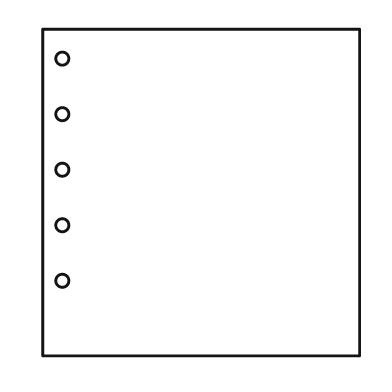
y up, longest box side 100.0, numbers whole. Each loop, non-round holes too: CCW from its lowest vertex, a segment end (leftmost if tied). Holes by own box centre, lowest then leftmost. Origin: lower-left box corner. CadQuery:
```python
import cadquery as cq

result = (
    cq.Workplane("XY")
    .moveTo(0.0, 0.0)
    .lineTo(97.0, 0.0)
    .lineTo(97.0, 100.0)
    .lineTo(0.0, 100.0)
    .close()
    .moveTo(6.0, 23.0)
    .circle(2.0)
    .moveTo(6.0, 40.0)
    .circle(2.0)
    .moveTo(6.0, 57.0)
    .circle(2.0)
    .moveTo(6.0, 74.0)
    .circle(2.0)
    .moveTo(6.0, 91.0)
    .circle(2.0)
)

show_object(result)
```